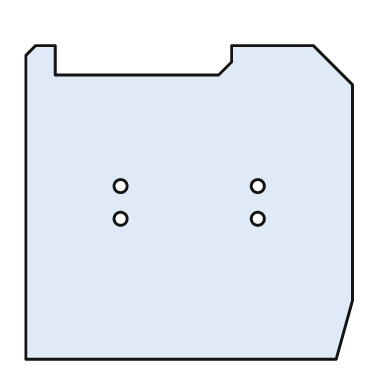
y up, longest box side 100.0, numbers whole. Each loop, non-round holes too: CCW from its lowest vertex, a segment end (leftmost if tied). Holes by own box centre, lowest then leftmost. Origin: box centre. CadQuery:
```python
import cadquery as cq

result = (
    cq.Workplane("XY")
    .moveTo(-50.0, -48.0)
    .lineTo(45.0, -48.0)
    .lineTo(50.0, -30.0)
    .lineTo(50.0, 36.0)
    .lineTo(38.0, 48.0)
    .lineTo(13.0, 48.0)
    .lineTo(13.0, 43.0)
    .lineTo(9.0, 39.0)
    .lineTo(-41.0, 39.0)
    .lineTo(-41.0, 48.0)
    .lineTo(-47.0, 48.0)
    .lineTo(-50.0, 45.0)
    .close()
    .moveTo(-21.0, -5.0)
    .circle(2.0)
    .moveTo(21.0, -5.0)
    .circle(2.0)
    .moveTo(-21.0, 5.0)
    .circle(2.0)
    .moveTo(21.0, 5.0)
    .circle(2.0)
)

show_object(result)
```